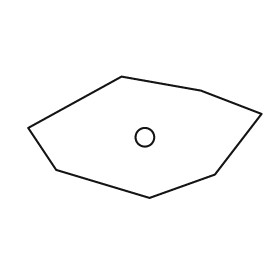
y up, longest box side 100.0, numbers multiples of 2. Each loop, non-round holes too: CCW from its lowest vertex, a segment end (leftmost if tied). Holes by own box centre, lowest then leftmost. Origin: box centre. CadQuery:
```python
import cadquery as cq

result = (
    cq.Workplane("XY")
    .moveTo(2.0, -26.0)
    .lineTo(30.0, -16.0)
    .lineTo(50.0, 10.0)
    .lineTo(24.0, 20.0)
    .lineTo(-10.0, 26.0)
    .lineTo(-50.0, 4.0)
    .lineTo(-38.0, -14.0)
    .close()
    .moveTo(0.0, 0.0)
    .circle(4.0)
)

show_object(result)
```